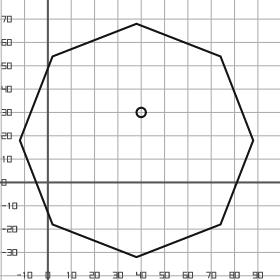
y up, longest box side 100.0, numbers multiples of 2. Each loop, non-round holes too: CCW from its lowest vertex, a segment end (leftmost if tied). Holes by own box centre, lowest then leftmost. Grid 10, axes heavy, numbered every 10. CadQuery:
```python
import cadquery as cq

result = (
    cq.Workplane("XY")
    .moveTo(38.0, -32.0)
    .lineTo(74.0, -18.0)
    .lineTo(88.0, 18.0)
    .lineTo(74.0, 54.0)
    .lineTo(38.0, 68.0)
    .lineTo(2.0, 54.0)
    .lineTo(-12.0, 18.0)
    .lineTo(2.0, -18.0)
    .close()
    .moveTo(40.0, 30.0)
    .circle(2.0)
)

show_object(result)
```